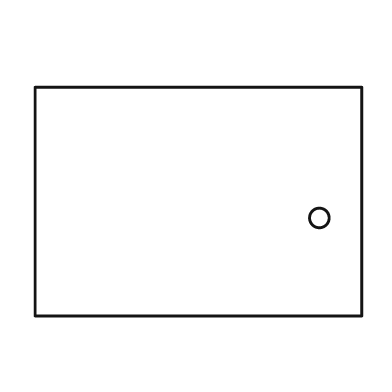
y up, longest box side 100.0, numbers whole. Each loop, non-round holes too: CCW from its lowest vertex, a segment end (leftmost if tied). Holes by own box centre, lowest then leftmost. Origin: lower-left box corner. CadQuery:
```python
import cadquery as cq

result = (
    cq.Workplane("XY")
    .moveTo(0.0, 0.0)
    .lineTo(100.0, 0.0)
    .lineTo(100.0, 70.0)
    .lineTo(0.0, 70.0)
    .close()
    .moveTo(87.0, 30.0)
    .circle(3.0)
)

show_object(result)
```